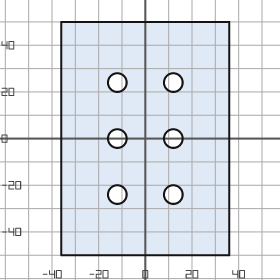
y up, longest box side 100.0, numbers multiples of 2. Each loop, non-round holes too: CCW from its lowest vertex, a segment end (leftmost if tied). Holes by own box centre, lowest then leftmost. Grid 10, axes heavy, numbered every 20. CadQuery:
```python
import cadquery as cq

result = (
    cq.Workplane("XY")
    .moveTo(-36.0, -50.0)
    .lineTo(36.0, -50.0)
    .lineTo(36.0, 50.0)
    .lineTo(-36.0, 50.0)
    .close()
    .moveTo(-12.0, -24.0)
    .circle(4.0)
    .moveTo(12.0, -24.0)
    .circle(4.0)
    .moveTo(-12.0, 0.0)
    .circle(4.0)
    .moveTo(12.0, 0.0)
    .circle(4.0)
    .moveTo(-12.0, 24.0)
    .circle(4.0)
    .moveTo(12.0, 24.0)
    .circle(4.0)
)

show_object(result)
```